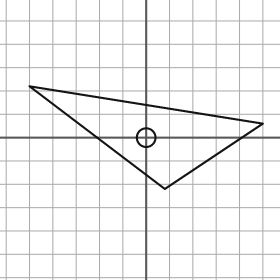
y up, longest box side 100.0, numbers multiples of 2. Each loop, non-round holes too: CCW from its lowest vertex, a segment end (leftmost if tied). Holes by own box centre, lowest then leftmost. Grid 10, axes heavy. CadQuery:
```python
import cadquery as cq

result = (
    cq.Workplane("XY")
    .moveTo(8.0, -22.0)
    .lineTo(50.0, 6.0)
    .lineTo(-50.0, 22.0)
    .close()
    .moveTo(0.0, 0.0)
    .circle(4.0)
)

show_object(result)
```